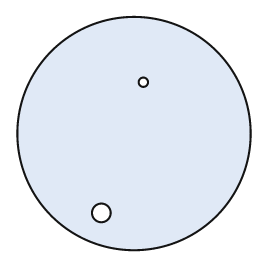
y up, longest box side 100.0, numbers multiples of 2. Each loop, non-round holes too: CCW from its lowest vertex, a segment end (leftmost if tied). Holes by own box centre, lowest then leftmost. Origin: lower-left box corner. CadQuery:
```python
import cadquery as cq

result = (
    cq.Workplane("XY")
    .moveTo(50.0, 50.0)
    .circle(50.0)
    .moveTo(36.0, 16.0)
    .circle(4.0)
    .moveTo(54.0, 72.0)
    .circle(2.0)
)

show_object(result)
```